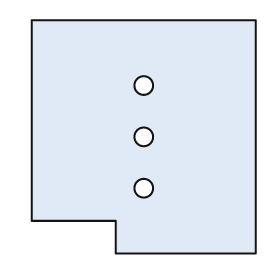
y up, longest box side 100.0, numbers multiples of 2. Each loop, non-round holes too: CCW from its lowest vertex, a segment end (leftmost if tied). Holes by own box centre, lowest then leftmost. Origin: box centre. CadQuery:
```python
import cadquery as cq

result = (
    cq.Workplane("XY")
    .moveTo(-12.0, -50.0)
    .lineTo(48.0, -50.0)
    .lineTo(48.0, 50.0)
    .lineTo(-48.0, 50.0)
    .lineTo(-48.0, -36.0)
    .lineTo(-12.0, -36.0)
    .close()
    .moveTo(0.0, -22.0)
    .circle(4.0)
    .moveTo(0.0, 0.0)
    .circle(4.0)
    .moveTo(0.0, 22.0)
    .circle(4.0)
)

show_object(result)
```